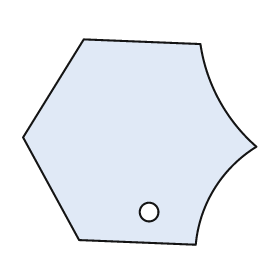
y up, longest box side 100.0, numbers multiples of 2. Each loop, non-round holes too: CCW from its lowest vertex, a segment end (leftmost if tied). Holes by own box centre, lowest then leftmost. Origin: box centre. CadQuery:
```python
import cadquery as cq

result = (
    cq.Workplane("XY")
    .moveTo(24.0, -44.0)
    .threePointArc((32.0, -20.0), (50.0, -2.0))
    .threePointArc((34.0, 18.0), (26.0, 42.0))
    .lineTo(-24.0, 44.0)
    .lineTo(-50.0, 2.0)
    .lineTo(-26.0, -42.0)
    .close()
    .moveTo(4.0, -30.0)
    .circle(4.0)
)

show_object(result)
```